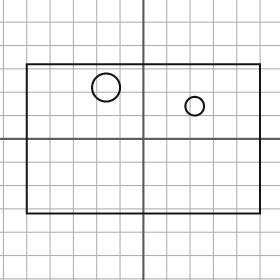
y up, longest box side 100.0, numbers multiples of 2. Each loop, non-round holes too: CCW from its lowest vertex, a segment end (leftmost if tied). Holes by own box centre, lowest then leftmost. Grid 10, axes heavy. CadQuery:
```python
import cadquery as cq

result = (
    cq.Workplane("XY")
    .moveTo(-50.0, -32.0)
    .lineTo(50.0, -32.0)
    .lineTo(50.0, 32.0)
    .lineTo(-50.0, 32.0)
    .close()
    .moveTo(22.0, 14.0)
    .circle(4.0)
    .moveTo(-16.0, 22.0)
    .circle(6.0)
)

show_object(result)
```